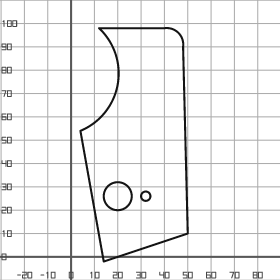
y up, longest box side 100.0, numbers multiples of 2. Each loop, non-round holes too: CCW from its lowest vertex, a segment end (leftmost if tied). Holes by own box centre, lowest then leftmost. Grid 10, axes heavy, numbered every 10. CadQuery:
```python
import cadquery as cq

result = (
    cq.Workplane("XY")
    .moveTo(14.0, -2.0)
    .lineTo(50.0, 10.0)
    .lineTo(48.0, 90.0)
    .threePointArc((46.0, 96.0), (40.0, 98.0))
    .lineTo(12.0, 98.0)
    .threePointArc((20.0, 74.0), (4.0, 54.0))
    .close()
    .moveTo(20.0, 26.0)
    .circle(6.0)
    .moveTo(32.0, 26.0)
    .circle(2.0)
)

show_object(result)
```